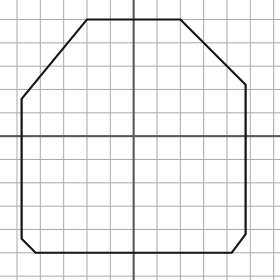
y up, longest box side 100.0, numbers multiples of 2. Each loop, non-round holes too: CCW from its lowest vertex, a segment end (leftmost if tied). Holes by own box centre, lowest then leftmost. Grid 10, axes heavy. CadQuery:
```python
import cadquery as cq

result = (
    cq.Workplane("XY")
    .moveTo(-42.0, -50.0)
    .lineTo(42.0, -50.0)
    .lineTo(48.0, -42.0)
    .lineTo(48.0, 22.0)
    .lineTo(20.0, 50.0)
    .lineTo(-20.0, 50.0)
    .lineTo(-48.0, 16.0)
    .lineTo(-48.0, -44.0)
    .close()
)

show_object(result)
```